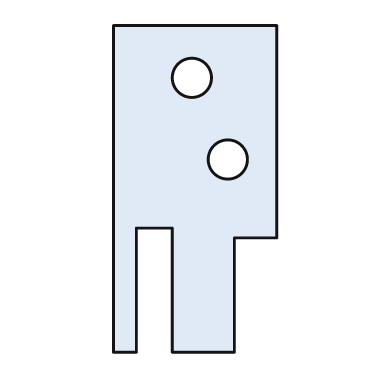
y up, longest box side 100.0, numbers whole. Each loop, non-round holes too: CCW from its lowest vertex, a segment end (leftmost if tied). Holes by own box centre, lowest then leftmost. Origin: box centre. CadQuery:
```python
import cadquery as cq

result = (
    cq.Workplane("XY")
    .moveTo(-25.0, -50.0)
    .lineTo(-18.0, -50.0)
    .lineTo(-18.0, -12.0)
    .lineTo(-7.0, -12.0)
    .lineTo(-7.0, -50.0)
    .lineTo(12.0, -50.0)
    .lineTo(12.0, -15.0)
    .lineTo(25.0, -15.0)
    .lineTo(25.0, 50.0)
    .lineTo(-25.0, 50.0)
    .close()
    .moveTo(10.0, 9.0)
    .circle(6.0)
    .moveTo(-1.0, 34.0)
    .circle(6.0)
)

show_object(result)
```